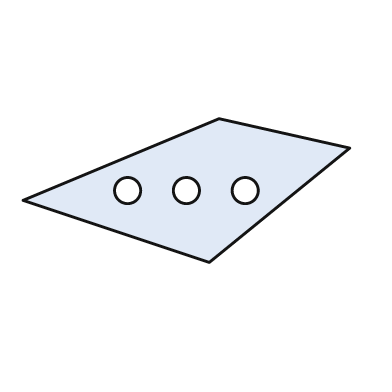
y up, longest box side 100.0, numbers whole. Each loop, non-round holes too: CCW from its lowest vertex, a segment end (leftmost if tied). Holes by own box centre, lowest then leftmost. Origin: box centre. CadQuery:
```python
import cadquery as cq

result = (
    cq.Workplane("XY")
    .moveTo(7.0, -22.0)
    .lineTo(50.0, 13.0)
    .lineTo(10.0, 22.0)
    .lineTo(-50.0, -3.0)
    .close()
    .moveTo(-18.0, 0.0)
    .circle(4.0)
    .moveTo(0.0, 0.0)
    .circle(4.0)
    .moveTo(18.0, 0.0)
    .circle(4.0)
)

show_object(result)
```